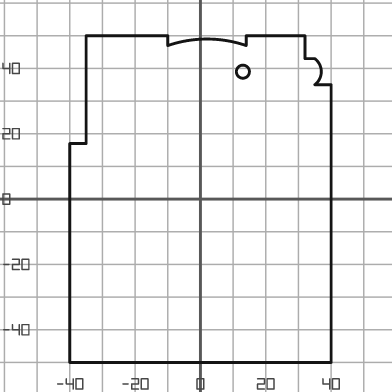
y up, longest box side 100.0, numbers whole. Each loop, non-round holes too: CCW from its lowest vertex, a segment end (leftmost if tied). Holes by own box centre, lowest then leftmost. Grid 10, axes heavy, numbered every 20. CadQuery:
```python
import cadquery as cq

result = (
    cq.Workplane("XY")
    .moveTo(-40.0, -50.0)
    .lineTo(40.0, -50.0)
    .lineTo(40.0, 35.0)
    .lineTo(35.0, 35.0)
    .threePointArc((37.0, 39.0), (35.0, 43.0))
    .lineTo(32.0, 43.0)
    .lineTo(32.0, 50.0)
    .lineTo(14.0, 50.0)
    .lineTo(14.0, 47.0)
    .threePointArc((2.0, 49.0), (-10.0, 47.0))
    .lineTo(-10.0, 50.0)
    .lineTo(-35.0, 50.0)
    .lineTo(-35.0, 17.0)
    .lineTo(-40.0, 17.0)
    .close()
    .moveTo(13.0, 39.0)
    .circle(2.0)
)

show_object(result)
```